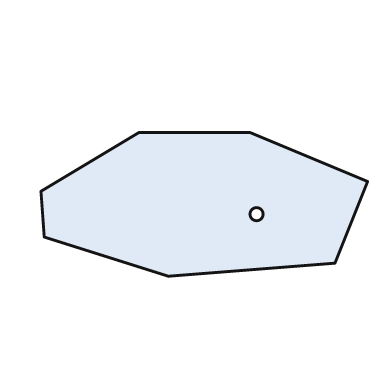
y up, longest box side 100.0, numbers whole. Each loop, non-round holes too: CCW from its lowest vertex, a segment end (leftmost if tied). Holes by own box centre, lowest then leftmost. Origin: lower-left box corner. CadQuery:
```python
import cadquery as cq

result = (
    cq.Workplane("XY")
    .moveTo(39.0, 0.0)
    .lineTo(90.0, 4.0)
    .lineTo(100.0, 29.0)
    .lineTo(64.0, 44.0)
    .lineTo(30.0, 44.0)
    .lineTo(0.0, 26.0)
    .lineTo(1.0, 12.0)
    .close()
    .moveTo(66.0, 19.0)
    .circle(2.0)
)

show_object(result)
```